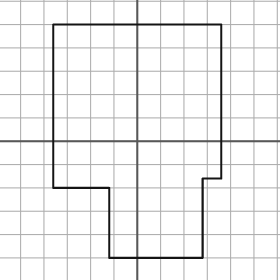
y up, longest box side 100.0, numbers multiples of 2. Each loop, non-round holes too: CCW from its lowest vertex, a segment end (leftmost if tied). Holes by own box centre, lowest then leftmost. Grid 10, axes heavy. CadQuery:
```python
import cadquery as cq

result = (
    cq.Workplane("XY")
    .moveTo(-12.0, -50.0)
    .lineTo(28.0, -50.0)
    .lineTo(28.0, -16.0)
    .lineTo(36.0, -16.0)
    .lineTo(36.0, 50.0)
    .lineTo(-36.0, 50.0)
    .lineTo(-36.0, -20.0)
    .lineTo(-12.0, -20.0)
    .close()
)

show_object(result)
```